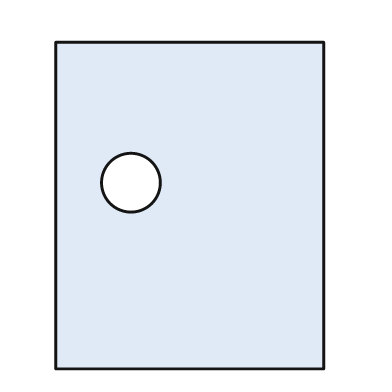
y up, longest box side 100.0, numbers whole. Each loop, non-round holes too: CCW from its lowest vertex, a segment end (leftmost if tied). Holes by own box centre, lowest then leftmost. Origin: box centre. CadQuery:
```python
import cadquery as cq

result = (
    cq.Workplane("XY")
    .moveTo(-41.0, -50.0)
    .lineTo(41.0, -50.0)
    .lineTo(41.0, 50.0)
    .lineTo(-41.0, 50.0)
    .close()
    .moveTo(-18.0, 7.0)
    .circle(9.0)
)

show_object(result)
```